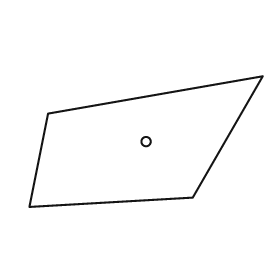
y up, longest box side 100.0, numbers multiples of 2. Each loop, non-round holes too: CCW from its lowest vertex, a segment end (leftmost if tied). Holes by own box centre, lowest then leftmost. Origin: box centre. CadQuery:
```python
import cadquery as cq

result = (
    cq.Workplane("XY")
    .moveTo(-50.0, -28.0)
    .lineTo(20.0, -24.0)
    .lineTo(50.0, 28.0)
    .lineTo(-42.0, 12.0)
    .close()
    .moveTo(0.0, 0.0)
    .circle(2.0)
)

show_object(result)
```